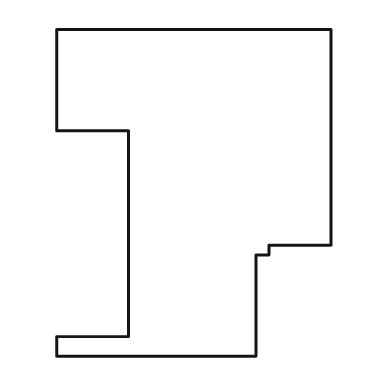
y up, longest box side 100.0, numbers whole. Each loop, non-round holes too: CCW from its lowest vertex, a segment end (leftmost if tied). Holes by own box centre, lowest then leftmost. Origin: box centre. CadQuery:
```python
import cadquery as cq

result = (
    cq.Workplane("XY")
    .moveTo(-42.0, -50.0)
    .lineTo(19.0, -50.0)
    .lineTo(19.0, -19.0)
    .lineTo(23.0, -19.0)
    .lineTo(23.0, -16.0)
    .lineTo(42.0, -16.0)
    .lineTo(42.0, 50.0)
    .lineTo(-42.0, 50.0)
    .lineTo(-42.0, 19.0)
    .lineTo(-20.0, 19.0)
    .lineTo(-20.0, -44.0)
    .lineTo(-42.0, -44.0)
    .close()
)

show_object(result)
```